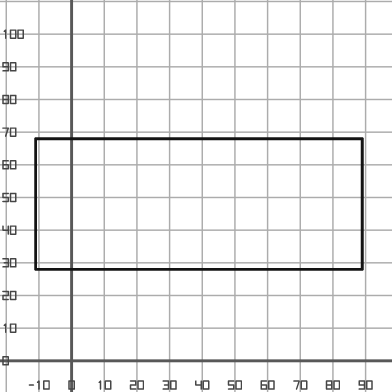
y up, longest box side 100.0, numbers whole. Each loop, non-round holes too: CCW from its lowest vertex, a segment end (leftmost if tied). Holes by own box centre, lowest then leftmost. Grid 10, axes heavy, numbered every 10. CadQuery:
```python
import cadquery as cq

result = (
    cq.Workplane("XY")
    .moveTo(-11.0, 28.0)
    .lineTo(89.0, 28.0)
    .lineTo(89.0, 68.0)
    .lineTo(-11.0, 68.0)
    .close()
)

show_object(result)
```